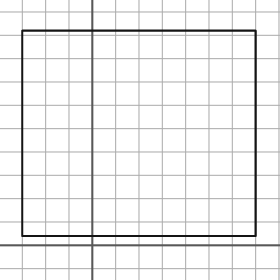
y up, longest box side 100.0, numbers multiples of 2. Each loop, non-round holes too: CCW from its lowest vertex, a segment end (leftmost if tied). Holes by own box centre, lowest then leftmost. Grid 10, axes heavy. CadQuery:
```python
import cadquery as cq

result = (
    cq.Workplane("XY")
    .moveTo(-30.0, 4.0)
    .lineTo(70.0, 4.0)
    .lineTo(70.0, 92.0)
    .lineTo(-30.0, 92.0)
    .close()
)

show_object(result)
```